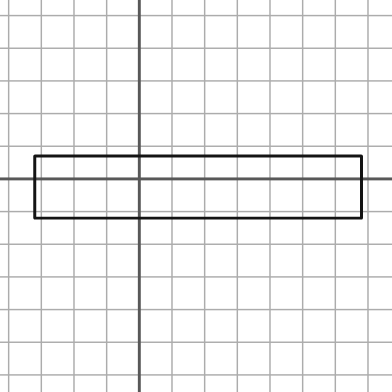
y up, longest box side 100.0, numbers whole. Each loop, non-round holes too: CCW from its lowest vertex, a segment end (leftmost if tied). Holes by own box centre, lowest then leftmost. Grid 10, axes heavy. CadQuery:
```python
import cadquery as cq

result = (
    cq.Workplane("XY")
    .moveTo(-32.0, -12.0)
    .lineTo(68.0, -12.0)
    .lineTo(68.0, 7.0)
    .lineTo(-32.0, 7.0)
    .close()
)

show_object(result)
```